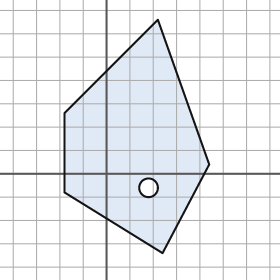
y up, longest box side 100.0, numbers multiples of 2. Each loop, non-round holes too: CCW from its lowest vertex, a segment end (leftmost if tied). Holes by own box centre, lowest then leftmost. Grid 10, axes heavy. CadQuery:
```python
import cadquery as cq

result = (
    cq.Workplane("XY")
    .moveTo(24.0, -34.0)
    .lineTo(44.0, 4.0)
    .lineTo(22.0, 66.0)
    .lineTo(-18.0, 26.0)
    .lineTo(-18.0, -8.0)
    .close()
    .moveTo(18.0, -6.0)
    .circle(4.0)
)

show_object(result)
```